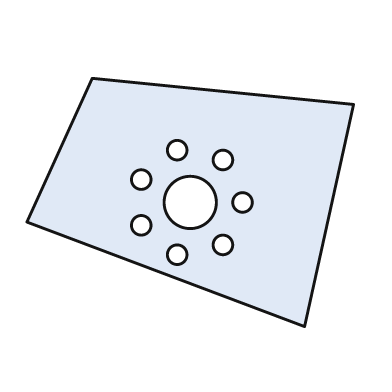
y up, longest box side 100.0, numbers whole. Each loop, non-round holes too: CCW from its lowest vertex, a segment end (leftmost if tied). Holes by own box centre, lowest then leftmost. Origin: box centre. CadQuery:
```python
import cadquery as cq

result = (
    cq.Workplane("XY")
    .moveTo(35.0, -38.0)
    .lineTo(50.0, 30.0)
    .lineTo(-30.0, 38.0)
    .lineTo(-50.0, -6.0)
    .close()
    .moveTo(-4.0, -16.0)
    .circle(3.0)
    .moveTo(10.0, -13.0)
    .circle(3.0)
    .moveTo(-15.0, -7.0)
    .circle(3.0)
    .moveTo(0.0, 0.0)
    .circle(8.0)
    .moveTo(16.0, 0.0)
    .circle(3.0)
    .moveTo(-15.0, 7.0)
    .circle(3.0)
    .moveTo(10.0, 13.0)
    .circle(3.0)
    .moveTo(-4.0, 16.0)
    .circle(3.0)
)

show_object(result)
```